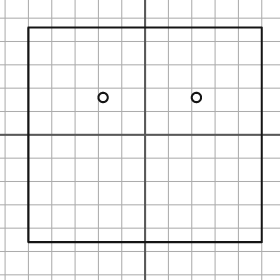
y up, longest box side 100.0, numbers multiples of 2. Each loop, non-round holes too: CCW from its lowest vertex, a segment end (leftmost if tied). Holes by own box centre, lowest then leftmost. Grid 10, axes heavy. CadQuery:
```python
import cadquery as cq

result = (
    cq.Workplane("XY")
    .moveTo(-50.0, -46.0)
    .lineTo(50.0, -46.0)
    .lineTo(50.0, 46.0)
    .lineTo(-50.0, 46.0)
    .close()
    .moveTo(-18.0, 16.0)
    .circle(2.0)
    .moveTo(22.0, 16.0)
    .circle(2.0)
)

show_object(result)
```